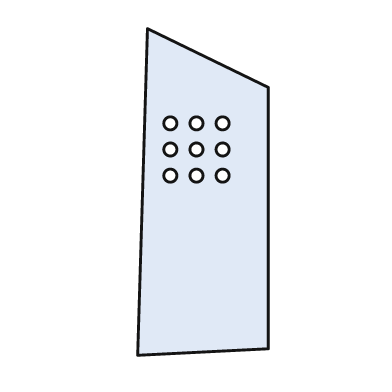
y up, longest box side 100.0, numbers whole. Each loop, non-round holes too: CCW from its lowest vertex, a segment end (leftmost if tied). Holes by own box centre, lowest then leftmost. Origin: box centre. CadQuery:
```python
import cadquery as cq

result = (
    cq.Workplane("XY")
    .moveTo(-20.0, -50.0)
    .lineTo(20.0, -48.0)
    .lineTo(20.0, 32.0)
    .lineTo(-17.0, 50.0)
    .close()
    .moveTo(-10.0, 5.0)
    .circle(2.0)
    .moveTo(-2.0, 5.0)
    .circle(2.0)
    .moveTo(6.0, 5.0)
    .circle(2.0)
    .moveTo(-10.0, 13.0)
    .circle(2.0)
    .moveTo(-2.0, 13.0)
    .circle(2.0)
    .moveTo(6.0, 13.0)
    .circle(2.0)
    .moveTo(-10.0, 21.0)
    .circle(2.0)
    .moveTo(-2.0, 21.0)
    .circle(2.0)
    .moveTo(6.0, 21.0)
    .circle(2.0)
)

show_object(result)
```